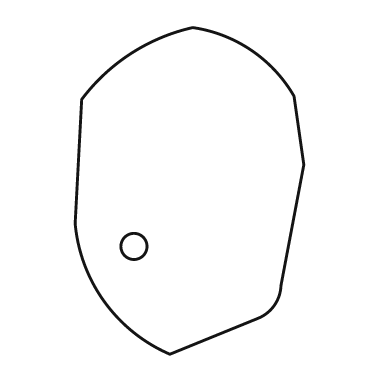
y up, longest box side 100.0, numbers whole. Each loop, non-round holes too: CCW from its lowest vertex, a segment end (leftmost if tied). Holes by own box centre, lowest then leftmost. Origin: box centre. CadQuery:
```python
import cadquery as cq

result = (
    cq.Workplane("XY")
    .moveTo(-6.0, -50.0)
    .lineTo(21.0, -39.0)
    .threePointArc((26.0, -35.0), (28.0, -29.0))
    .lineTo(35.0, 8.0)
    .lineTo(32.0, 29.0)
    .threePointArc((19.0, 43.0), (1.0, 50.0))
    .threePointArc((-18.0, 42.0), (-33.0, 28.0))
    .lineTo(-35.0, -10.0)
    .threePointArc((-26.0, -34.0), (-6.0, -50.0))
    .close()
    .moveTo(-17.0, -17.0)
    .circle(4.0)
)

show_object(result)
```